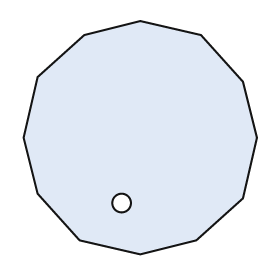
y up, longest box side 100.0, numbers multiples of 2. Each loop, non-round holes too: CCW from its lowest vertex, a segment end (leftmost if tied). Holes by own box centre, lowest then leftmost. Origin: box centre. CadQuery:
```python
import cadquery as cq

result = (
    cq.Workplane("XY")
    .moveTo(0.0, -50.0)
    .lineTo(24.0, -44.0)
    .lineTo(44.0, -26.0)
    .lineTo(50.0, 0.0)
    .lineTo(44.0, 24.0)
    .lineTo(26.0, 44.0)
    .lineTo(0.0, 50.0)
    .lineTo(-24.0, 44.0)
    .lineTo(-44.0, 26.0)
    .lineTo(-50.0, 0.0)
    .lineTo(-44.0, -24.0)
    .lineTo(-26.0, -44.0)
    .close()
    .moveTo(-8.0, -28.0)
    .circle(4.0)
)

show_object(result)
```